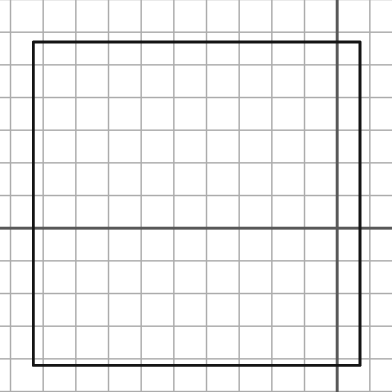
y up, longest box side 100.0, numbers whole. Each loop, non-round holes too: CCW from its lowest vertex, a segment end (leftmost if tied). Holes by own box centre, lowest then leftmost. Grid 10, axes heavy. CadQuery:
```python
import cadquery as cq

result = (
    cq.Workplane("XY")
    .moveTo(-93.0, -42.0)
    .lineTo(7.0, -42.0)
    .lineTo(7.0, 57.0)
    .lineTo(-93.0, 57.0)
    .close()
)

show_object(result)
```